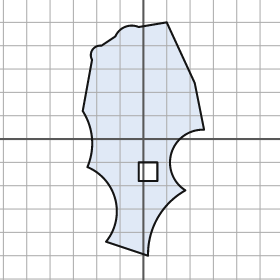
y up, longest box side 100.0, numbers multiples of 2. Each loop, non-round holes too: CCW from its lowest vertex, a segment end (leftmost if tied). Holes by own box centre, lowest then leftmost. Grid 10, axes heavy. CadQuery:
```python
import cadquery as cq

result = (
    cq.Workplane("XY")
    .moveTo(2.0, -50.0)
    .threePointArc((6.0, -34.0), (18.0, -22.0))
    .threePointArc((12.0, -6.0), (26.0, 4.0))
    .lineTo(22.0, 24.0)
    .lineTo(10.0, 50.0)
    .lineTo(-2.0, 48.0)
    .threePointArc((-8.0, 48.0), (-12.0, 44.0))
    .lineTo(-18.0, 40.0)
    .threePointArc((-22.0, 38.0), (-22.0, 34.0))
    .lineTo(-26.0, 12.0)
    .threePointArc((-22.0, 0.0), (-24.0, -12.0))
    .threePointArc((-12.0, -26.0), (-16.0, -44.0))
    .close()
    .moveTo(-2.0, -18.0)
    .lineTo(6.0, -18.0)
    .lineTo(6.0, -10.0)
    .lineTo(-2.0, -10.0)
    .close()
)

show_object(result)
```